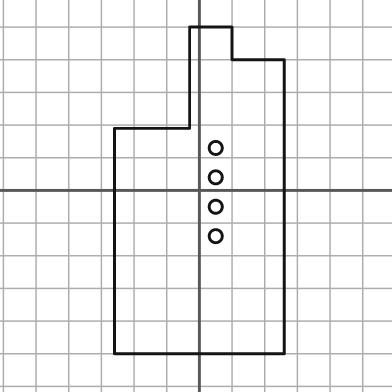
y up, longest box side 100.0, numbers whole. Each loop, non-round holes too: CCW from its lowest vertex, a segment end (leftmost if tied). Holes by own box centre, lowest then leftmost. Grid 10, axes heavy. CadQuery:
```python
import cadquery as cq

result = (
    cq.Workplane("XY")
    .moveTo(-26.0, -50.0)
    .lineTo(26.0, -50.0)
    .lineTo(26.0, 40.0)
    .lineTo(10.0, 40.0)
    .lineTo(10.0, 50.0)
    .lineTo(-3.0, 50.0)
    .lineTo(-3.0, 19.0)
    .lineTo(-26.0, 19.0)
    .close()
    .moveTo(5.0, -14.0)
    .circle(2.0)
    .moveTo(5.0, -5.0)
    .circle(2.0)
    .moveTo(5.0, 4.0)
    .circle(2.0)
    .moveTo(5.0, 13.0)
    .circle(2.0)
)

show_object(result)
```